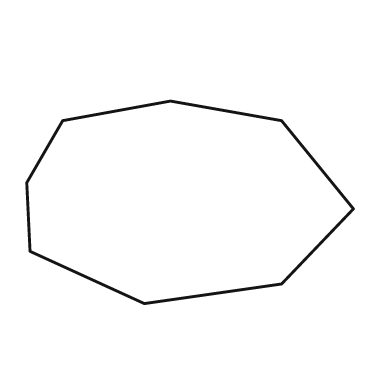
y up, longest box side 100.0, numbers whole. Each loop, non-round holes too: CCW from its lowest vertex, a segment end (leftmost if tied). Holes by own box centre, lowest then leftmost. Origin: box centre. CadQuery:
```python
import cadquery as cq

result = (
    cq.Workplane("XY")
    .moveTo(-14.0, -31.0)
    .lineTo(28.0, -25.0)
    .lineTo(50.0, -2.0)
    .lineTo(28.0, 25.0)
    .lineTo(-6.0, 31.0)
    .lineTo(-39.0, 25.0)
    .lineTo(-50.0, 6.0)
    .lineTo(-49.0, -15.0)
    .close()
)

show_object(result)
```